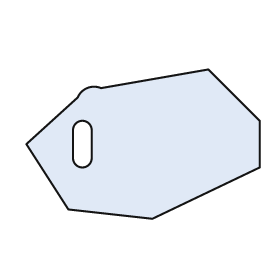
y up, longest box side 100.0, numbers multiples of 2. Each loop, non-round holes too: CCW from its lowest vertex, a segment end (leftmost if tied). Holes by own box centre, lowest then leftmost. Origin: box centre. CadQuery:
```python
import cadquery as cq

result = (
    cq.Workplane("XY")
    .moveTo(4.0, -32.0)
    .lineTo(50.0, -10.0)
    .lineTo(50.0, 10.0)
    .lineTo(28.0, 32.0)
    .lineTo(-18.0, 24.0)
    .threePointArc((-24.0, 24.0), (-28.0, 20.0))
    .lineTo(-50.0, 0.0)
    .lineTo(-32.0, -28.0)
    .close()
    .moveTo(-30.0, -6.0)
    .threePointArc((-26.0, -10.0), (-22.0, -6.0))
    .lineTo(-22.0, 6.0)
    .threePointArc((-26.0, 10.0), (-30.0, 6.0))
    .close()
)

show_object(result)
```